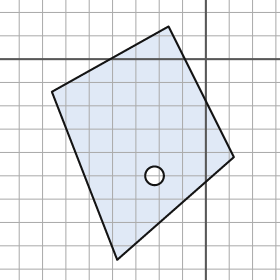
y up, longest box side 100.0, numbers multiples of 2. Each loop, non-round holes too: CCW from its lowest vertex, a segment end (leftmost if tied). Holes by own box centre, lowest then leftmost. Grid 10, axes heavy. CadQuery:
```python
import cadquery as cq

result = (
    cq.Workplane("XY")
    .moveTo(-38.0, -86.0)
    .lineTo(12.0, -42.0)
    .lineTo(-16.0, 14.0)
    .lineTo(-66.0, -14.0)
    .close()
    .moveTo(-22.0, -50.0)
    .circle(4.0)
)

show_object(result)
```